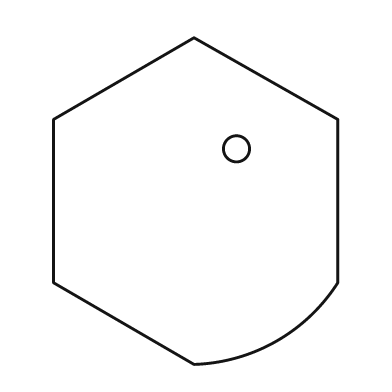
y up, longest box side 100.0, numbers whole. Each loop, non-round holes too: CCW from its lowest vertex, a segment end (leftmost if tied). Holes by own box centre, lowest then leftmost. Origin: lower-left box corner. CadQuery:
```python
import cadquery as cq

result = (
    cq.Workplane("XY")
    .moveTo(43.0, 0.0)
    .threePointArc((68.0, 7.0), (87.0, 25.0))
    .lineTo(87.0, 75.0)
    .lineTo(43.0, 100.0)
    .lineTo(0.0, 75.0)
    .lineTo(0.0, 25.0)
    .close()
    .moveTo(56.0, 66.0)
    .circle(4.0)
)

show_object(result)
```